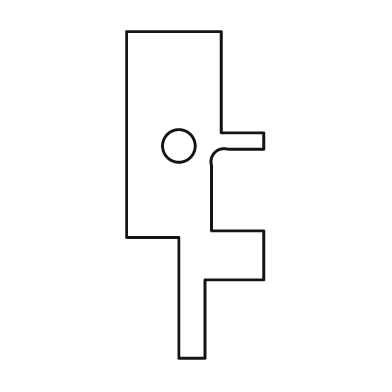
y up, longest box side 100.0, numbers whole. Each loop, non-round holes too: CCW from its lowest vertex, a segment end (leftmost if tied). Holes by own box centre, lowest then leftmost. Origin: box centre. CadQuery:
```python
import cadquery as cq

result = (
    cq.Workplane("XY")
    .moveTo(-5.0, -50.0)
    .lineTo(3.0, -50.0)
    .lineTo(3.0, -26.0)
    .lineTo(21.0, -26.0)
    .lineTo(21.0, -11.0)
    .lineTo(5.0, -11.0)
    .lineTo(5.0, 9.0)
    .threePointArc((6.0, 13.0), (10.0, 14.0))
    .lineTo(21.0, 14.0)
    .lineTo(21.0, 19.0)
    .lineTo(8.0, 19.0)
    .lineTo(8.0, 50.0)
    .lineTo(-21.0, 50.0)
    .lineTo(-21.0, -13.0)
    .lineTo(-5.0, -13.0)
    .close()
    .moveTo(-5.0, 15.0)
    .circle(5.0)
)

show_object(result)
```